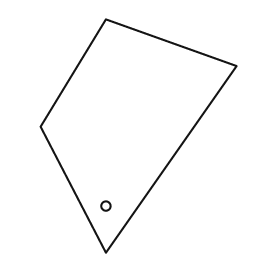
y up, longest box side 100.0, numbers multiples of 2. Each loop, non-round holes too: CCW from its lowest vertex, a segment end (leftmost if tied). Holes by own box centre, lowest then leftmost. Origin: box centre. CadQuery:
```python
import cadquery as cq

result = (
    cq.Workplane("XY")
    .moveTo(-14.0, -50.0)
    .lineTo(42.0, 30.0)
    .lineTo(-14.0, 50.0)
    .lineTo(-42.0, 4.0)
    .close()
    .moveTo(-14.0, -30.0)
    .circle(2.0)
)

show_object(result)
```